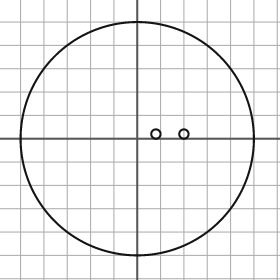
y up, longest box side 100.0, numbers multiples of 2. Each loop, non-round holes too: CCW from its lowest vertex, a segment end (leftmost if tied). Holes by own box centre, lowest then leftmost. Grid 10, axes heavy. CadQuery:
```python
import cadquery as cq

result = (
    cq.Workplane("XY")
    .moveTo(0.0, 0.0)
    .circle(50.0)
    .moveTo(8.0, 2.0)
    .circle(2.0)
    .moveTo(20.0, 2.0)
    .circle(2.0)
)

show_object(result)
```